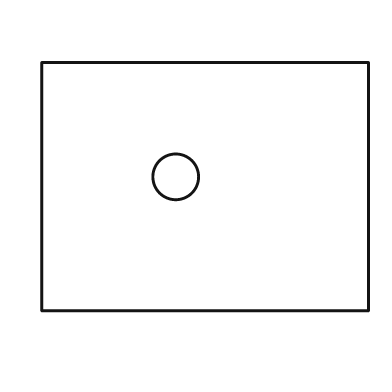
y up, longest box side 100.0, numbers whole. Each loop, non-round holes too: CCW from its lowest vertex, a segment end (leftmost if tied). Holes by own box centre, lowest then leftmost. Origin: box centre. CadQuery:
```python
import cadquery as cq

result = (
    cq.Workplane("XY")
    .moveTo(-50.0, -38.0)
    .lineTo(50.0, -38.0)
    .lineTo(50.0, 38.0)
    .lineTo(-50.0, 38.0)
    .close()
    .moveTo(-9.0, 3.0)
    .circle(7.0)
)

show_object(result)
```